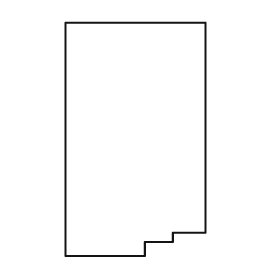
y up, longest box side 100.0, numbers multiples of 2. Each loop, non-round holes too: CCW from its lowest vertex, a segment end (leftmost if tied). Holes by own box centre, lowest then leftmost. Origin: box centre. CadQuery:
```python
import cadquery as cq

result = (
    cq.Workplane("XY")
    .moveTo(-30.0, -50.0)
    .lineTo(4.0, -50.0)
    .lineTo(4.0, -44.0)
    .lineTo(16.0, -44.0)
    .lineTo(16.0, -40.0)
    .lineTo(30.0, -40.0)
    .lineTo(30.0, 50.0)
    .lineTo(-30.0, 50.0)
    .close()
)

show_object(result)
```